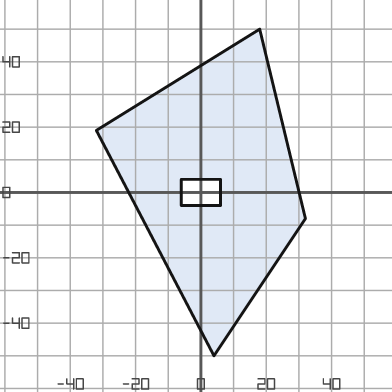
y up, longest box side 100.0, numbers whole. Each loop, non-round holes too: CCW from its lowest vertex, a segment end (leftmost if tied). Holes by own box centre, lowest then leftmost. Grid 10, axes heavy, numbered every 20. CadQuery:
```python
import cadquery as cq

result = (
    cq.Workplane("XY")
    .moveTo(4.0, -50.0)
    .lineTo(32.0, -8.0)
    .lineTo(18.0, 50.0)
    .lineTo(-32.0, 19.0)
    .close()
    .moveTo(-6.0, -4.0)
    .lineTo(6.0, -4.0)
    .lineTo(6.0, 4.0)
    .lineTo(-6.0, 4.0)
    .close()
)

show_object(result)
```